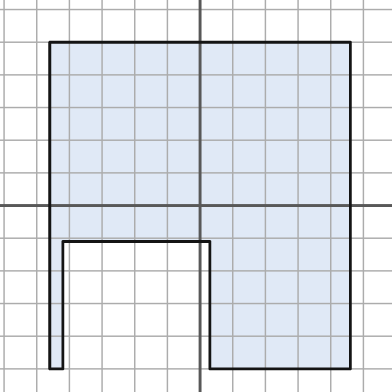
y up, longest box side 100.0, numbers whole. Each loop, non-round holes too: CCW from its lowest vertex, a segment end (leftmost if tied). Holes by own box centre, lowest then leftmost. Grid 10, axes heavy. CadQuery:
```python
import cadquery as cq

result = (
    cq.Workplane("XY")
    .moveTo(-46.0, -50.0)
    .lineTo(-42.0, -50.0)
    .lineTo(-42.0, -11.0)
    .lineTo(3.0, -11.0)
    .lineTo(3.0, -50.0)
    .lineTo(46.0, -50.0)
    .lineTo(46.0, 50.0)
    .lineTo(-46.0, 50.0)
    .close()
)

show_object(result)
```